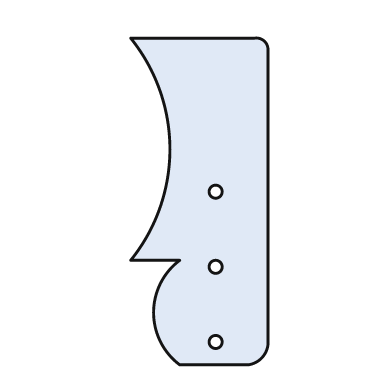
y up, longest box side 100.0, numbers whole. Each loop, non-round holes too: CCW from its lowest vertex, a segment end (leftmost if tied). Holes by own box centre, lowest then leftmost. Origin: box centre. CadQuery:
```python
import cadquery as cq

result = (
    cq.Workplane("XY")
    .moveTo(-6.0, -50.0)
    .lineTo(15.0, -50.0)
    .threePointArc((19.0, -48.0), (21.0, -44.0))
    .lineTo(21.0, 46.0)
    .threePointArc((20.0, 49.0), (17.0, 50.0))
    .lineTo(-21.0, 50.0)
    .threePointArc((-9.0, 16.0), (-21.0, -18.0))
    .lineTo(-6.0, -18.0)
    .threePointArc((-14.0, -34.0), (-6.0, -50.0))
    .close()
    .moveTo(5.0, -43.0)
    .circle(2.0)
    .moveTo(5.0, -20.0)
    .circle(2.0)
    .moveTo(5.0, 3.0)
    .circle(2.0)
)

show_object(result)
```